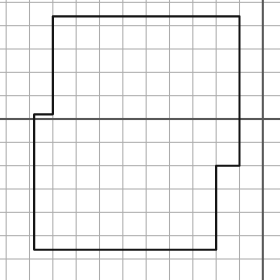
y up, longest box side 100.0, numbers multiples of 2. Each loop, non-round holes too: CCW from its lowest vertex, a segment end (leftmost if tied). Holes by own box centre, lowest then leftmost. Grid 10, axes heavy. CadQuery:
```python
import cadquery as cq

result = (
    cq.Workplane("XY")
    .moveTo(-98.0, -56.0)
    .lineTo(-20.0, -56.0)
    .lineTo(-20.0, -20.0)
    .lineTo(-10.0, -20.0)
    .lineTo(-10.0, 44.0)
    .lineTo(-90.0, 44.0)
    .lineTo(-90.0, 2.0)
    .lineTo(-98.0, 2.0)
    .close()
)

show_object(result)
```